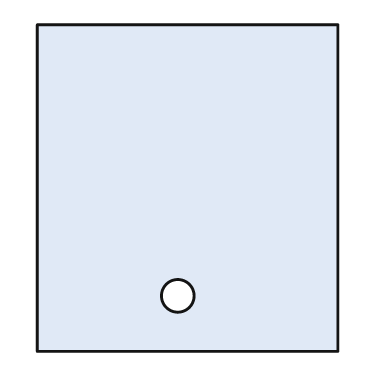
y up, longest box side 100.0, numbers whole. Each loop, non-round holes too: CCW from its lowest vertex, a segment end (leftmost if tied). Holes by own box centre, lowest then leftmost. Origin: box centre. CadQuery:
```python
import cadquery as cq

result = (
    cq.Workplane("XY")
    .moveTo(-46.0, -50.0)
    .lineTo(46.0, -50.0)
    .lineTo(46.0, 50.0)
    .lineTo(-46.0, 50.0)
    .close()
    .moveTo(-3.0, -33.0)
    .circle(5.0)
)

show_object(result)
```